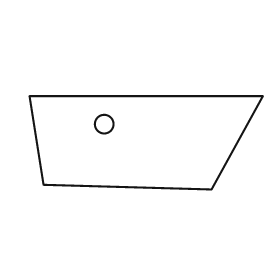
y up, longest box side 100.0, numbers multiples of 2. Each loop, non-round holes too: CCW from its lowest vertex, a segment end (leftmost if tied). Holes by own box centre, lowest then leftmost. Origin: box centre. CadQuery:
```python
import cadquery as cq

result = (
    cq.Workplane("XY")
    .moveTo(28.0, -20.0)
    .lineTo(50.0, 20.0)
    .lineTo(-50.0, 20.0)
    .lineTo(-44.0, -18.0)
    .close()
    .moveTo(-18.0, 8.0)
    .circle(4.0)
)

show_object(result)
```